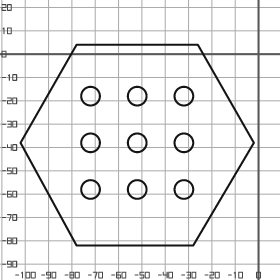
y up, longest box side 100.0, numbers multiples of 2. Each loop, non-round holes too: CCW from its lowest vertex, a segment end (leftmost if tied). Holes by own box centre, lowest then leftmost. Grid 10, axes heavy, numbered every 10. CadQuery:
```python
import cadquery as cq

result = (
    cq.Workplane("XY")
    .moveTo(-78.0, -82.0)
    .lineTo(-28.0, -82.0)
    .lineTo(-2.0, -38.0)
    .lineTo(-26.0, 4.0)
    .lineTo(-78.0, 4.0)
    .lineTo(-102.0, -38.0)
    .close()
    .moveTo(-72.0, -58.0)
    .circle(4.0)
    .moveTo(-52.0, -58.0)
    .circle(4.0)
    .moveTo(-32.0, -58.0)
    .circle(4.0)
    .moveTo(-72.0, -38.0)
    .circle(4.0)
    .moveTo(-52.0, -38.0)
    .circle(4.0)
    .moveTo(-32.0, -38.0)
    .circle(4.0)
    .moveTo(-72.0, -18.0)
    .circle(4.0)
    .moveTo(-52.0, -18.0)
    .circle(4.0)
    .moveTo(-32.0, -18.0)
    .circle(4.0)
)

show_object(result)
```